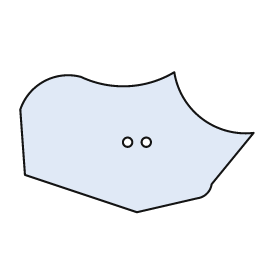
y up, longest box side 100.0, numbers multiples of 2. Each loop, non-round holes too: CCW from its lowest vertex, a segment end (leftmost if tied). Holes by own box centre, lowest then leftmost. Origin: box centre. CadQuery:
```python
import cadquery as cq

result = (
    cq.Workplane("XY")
    .moveTo(0.0, -30.0)
    .lineTo(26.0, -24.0)
    .threePointArc((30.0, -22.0), (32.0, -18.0))
    .lineTo(50.0, 4.0)
    .threePointArc((28.0, 10.0), (16.0, 30.0))
    .threePointArc((-4.0, 24.0), (-24.0, 28.0))
    .threePointArc((-40.0, 26.0), (-50.0, 14.0))
    .lineTo(-48.0, -14.0)
    .close()
    .moveTo(-4.0, 0.0)
    .circle(2.0)
    .moveTo(4.0, 0.0)
    .circle(2.0)
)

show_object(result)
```